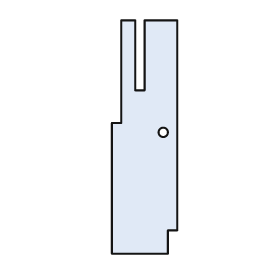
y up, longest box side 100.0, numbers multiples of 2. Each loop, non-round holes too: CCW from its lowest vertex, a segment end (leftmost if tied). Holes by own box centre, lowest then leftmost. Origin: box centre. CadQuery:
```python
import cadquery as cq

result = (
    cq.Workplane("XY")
    .moveTo(-14.0, -50.0)
    .lineTo(10.0, -50.0)
    .lineTo(10.0, -40.0)
    .lineTo(14.0, -40.0)
    .lineTo(14.0, 50.0)
    .lineTo(0.0, 50.0)
    .lineTo(0.0, 20.0)
    .lineTo(-4.0, 20.0)
    .lineTo(-4.0, 50.0)
    .lineTo(-10.0, 50.0)
    .lineTo(-10.0, 6.0)
    .lineTo(-14.0, 6.0)
    .close()
    .moveTo(8.0, 2.0)
    .circle(2.0)
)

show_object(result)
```